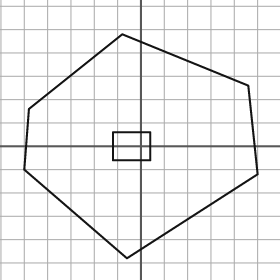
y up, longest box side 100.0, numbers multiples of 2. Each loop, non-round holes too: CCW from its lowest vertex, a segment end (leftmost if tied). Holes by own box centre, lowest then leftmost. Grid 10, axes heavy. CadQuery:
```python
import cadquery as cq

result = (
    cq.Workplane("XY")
    .moveTo(-6.0, -48.0)
    .lineTo(50.0, -12.0)
    .lineTo(46.0, 26.0)
    .lineTo(-8.0, 48.0)
    .lineTo(-48.0, 16.0)
    .lineTo(-50.0, -10.0)
    .close()
    .moveTo(-12.0, -6.0)
    .lineTo(4.0, -6.0)
    .lineTo(4.0, 6.0)
    .lineTo(-12.0, 6.0)
    .close()
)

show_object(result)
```